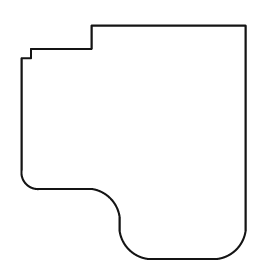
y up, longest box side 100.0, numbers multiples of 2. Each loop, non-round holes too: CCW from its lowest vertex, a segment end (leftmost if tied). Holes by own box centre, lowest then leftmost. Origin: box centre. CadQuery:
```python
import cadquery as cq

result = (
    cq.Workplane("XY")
    .moveTo(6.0, -50.0)
    .lineTo(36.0, -50.0)
    .threePointArc((44.0, -46.0), (48.0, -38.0))
    .lineTo(48.0, 50.0)
    .lineTo(-18.0, 50.0)
    .lineTo(-18.0, 40.0)
    .lineTo(-44.0, 40.0)
    .lineTo(-44.0, 36.0)
    .lineTo(-48.0, 36.0)
    .lineTo(-48.0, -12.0)
    .threePointArc((-46.0, -18.0), (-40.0, -20.0))
    .lineTo(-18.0, -20.0)
    .threePointArc((-10.0, -24.0), (-6.0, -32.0))
    .lineTo(-6.0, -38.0)
    .threePointArc((-2.0, -46.0), (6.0, -50.0))
    .close()
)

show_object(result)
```